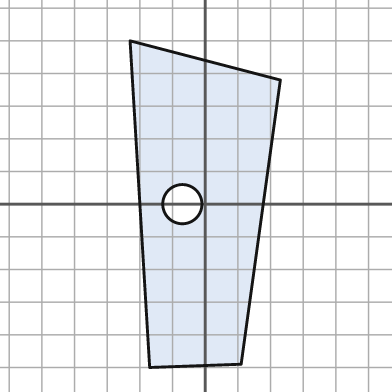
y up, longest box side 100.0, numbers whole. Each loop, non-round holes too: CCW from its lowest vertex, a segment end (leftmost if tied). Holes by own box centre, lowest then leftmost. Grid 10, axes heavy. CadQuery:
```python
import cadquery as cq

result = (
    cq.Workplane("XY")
    .moveTo(-17.0, -50.0)
    .lineTo(11.0, -49.0)
    .lineTo(23.0, 38.0)
    .lineTo(-23.0, 50.0)
    .close()
    .moveTo(-7.0, 0.0)
    .circle(6.0)
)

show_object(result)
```